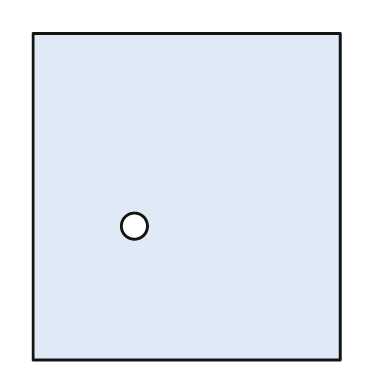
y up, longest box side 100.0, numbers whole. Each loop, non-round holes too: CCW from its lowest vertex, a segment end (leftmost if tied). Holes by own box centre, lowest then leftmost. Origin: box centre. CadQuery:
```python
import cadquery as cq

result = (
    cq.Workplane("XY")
    .moveTo(-47.0, -50.0)
    .lineTo(47.0, -50.0)
    .lineTo(47.0, 50.0)
    .lineTo(-47.0, 50.0)
    .close()
    .moveTo(-16.0, -9.0)
    .circle(4.0)
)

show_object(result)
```